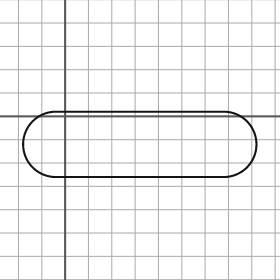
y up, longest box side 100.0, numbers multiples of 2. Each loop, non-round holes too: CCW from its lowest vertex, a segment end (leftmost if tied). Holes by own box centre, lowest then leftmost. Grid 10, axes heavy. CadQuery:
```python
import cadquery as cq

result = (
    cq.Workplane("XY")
    .moveTo(-4.0, -26.0)
    .lineTo(68.0, -26.0)
    .threePointArc((82.0, -12.0), (68.0, 2.0))
    .lineTo(-4.0, 2.0)
    .threePointArc((-18.0, -12.0), (-4.0, -26.0))
    .close()
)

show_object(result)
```